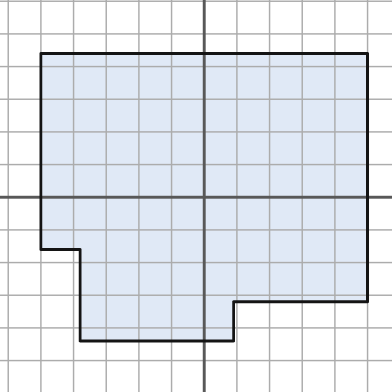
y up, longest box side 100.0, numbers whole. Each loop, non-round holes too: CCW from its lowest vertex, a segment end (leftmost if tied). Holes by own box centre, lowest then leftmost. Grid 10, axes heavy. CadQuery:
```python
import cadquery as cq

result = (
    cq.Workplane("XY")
    .moveTo(-38.0, -44.0)
    .lineTo(9.0, -44.0)
    .lineTo(9.0, -32.0)
    .lineTo(50.0, -32.0)
    .lineTo(50.0, 44.0)
    .lineTo(-50.0, 44.0)
    .lineTo(-50.0, -16.0)
    .lineTo(-38.0, -16.0)
    .close()
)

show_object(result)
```